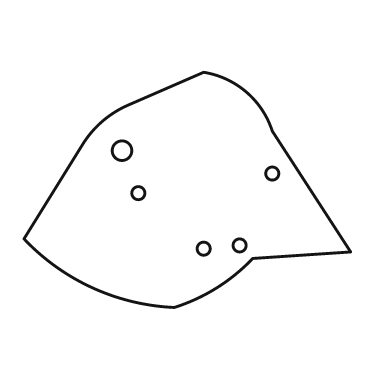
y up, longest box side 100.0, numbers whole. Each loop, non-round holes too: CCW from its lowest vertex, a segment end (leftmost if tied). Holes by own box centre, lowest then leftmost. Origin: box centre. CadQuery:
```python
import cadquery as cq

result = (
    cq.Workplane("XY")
    .moveTo(-4.0, -36.0)
    .threePointArc((9.0, -30.0), (20.0, -21.0))
    .lineTo(50.0, -19.0)
    .lineTo(26.0, 18.0)
    .threePointArc((18.0, 30.0), (5.0, 36.0))
    .lineTo(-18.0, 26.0)
    .threePointArc((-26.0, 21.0), (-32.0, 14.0))
    .lineTo(-50.0, -15.0)
    .threePointArc((-29.0, -30.0), (-4.0, -36.0))
    .close()
    .moveTo(5.0, -18.0)
    .circle(2.0)
    .moveTo(16.0, -17.0)
    .circle(2.0)
    .moveTo(-15.0, -1.0)
    .circle(2.0)
    .moveTo(26.0, 5.0)
    .circle(2.0)
    .moveTo(-20.0, 12.0)
    .circle(3.0)
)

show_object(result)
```